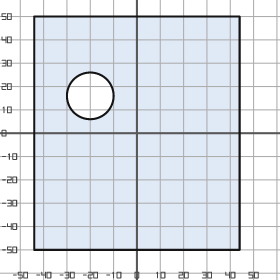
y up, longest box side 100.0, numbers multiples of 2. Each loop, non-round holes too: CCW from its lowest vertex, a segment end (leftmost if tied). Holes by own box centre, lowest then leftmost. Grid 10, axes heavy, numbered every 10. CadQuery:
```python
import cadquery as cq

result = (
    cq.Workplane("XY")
    .moveTo(-44.0, -50.0)
    .lineTo(44.0, -50.0)
    .lineTo(44.0, 50.0)
    .lineTo(-44.0, 50.0)
    .close()
    .moveTo(-20.0, 16.0)
    .circle(10.0)
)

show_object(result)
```